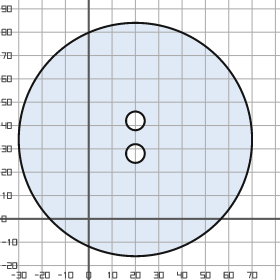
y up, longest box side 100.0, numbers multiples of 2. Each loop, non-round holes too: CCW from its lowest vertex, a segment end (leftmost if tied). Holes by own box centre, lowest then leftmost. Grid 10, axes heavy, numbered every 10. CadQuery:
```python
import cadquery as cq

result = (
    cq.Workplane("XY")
    .moveTo(20.0, 34.0)
    .circle(50.0)
    .moveTo(20.0, 28.0)
    .circle(4.0)
    .moveTo(20.0, 42.0)
    .circle(4.0)
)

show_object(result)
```